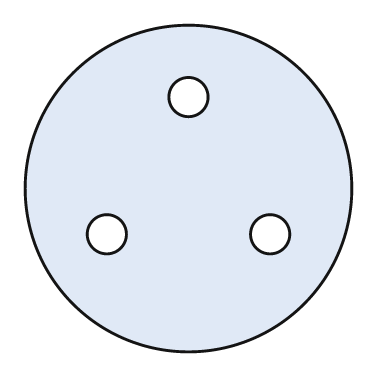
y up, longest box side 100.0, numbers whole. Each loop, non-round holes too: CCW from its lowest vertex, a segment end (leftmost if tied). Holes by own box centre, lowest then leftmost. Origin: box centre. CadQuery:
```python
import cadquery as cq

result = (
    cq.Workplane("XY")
    .moveTo(0.0, 0.0)
    .circle(50.0)
    .moveTo(-25.0, -14.0)
    .circle(6.0)
    .moveTo(25.0, -14.0)
    .circle(6.0)
    .moveTo(0.0, 28.0)
    .circle(6.0)
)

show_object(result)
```